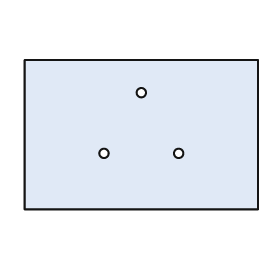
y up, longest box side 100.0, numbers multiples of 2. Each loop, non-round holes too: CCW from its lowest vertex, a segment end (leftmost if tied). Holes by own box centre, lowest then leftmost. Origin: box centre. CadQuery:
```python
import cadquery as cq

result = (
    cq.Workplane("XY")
    .moveTo(-50.0, -32.0)
    .lineTo(50.0, -32.0)
    .lineTo(50.0, 32.0)
    .lineTo(-50.0, 32.0)
    .close()
    .moveTo(-16.0, -8.0)
    .circle(2.0)
    .moveTo(16.0, -8.0)
    .circle(2.0)
    .moveTo(0.0, 18.0)
    .circle(2.0)
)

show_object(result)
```